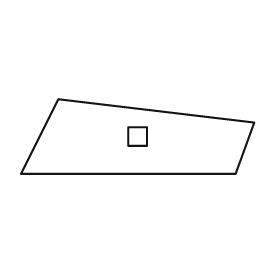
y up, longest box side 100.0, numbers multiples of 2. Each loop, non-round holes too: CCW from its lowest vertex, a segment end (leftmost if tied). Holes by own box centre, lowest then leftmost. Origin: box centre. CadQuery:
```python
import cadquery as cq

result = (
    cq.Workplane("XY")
    .moveTo(-50.0, -16.0)
    .lineTo(42.0, -16.0)
    .lineTo(50.0, 6.0)
    .lineTo(-34.0, 16.0)
    .close()
    .moveTo(-4.0, -4.0)
    .lineTo(4.0, -4.0)
    .lineTo(4.0, 4.0)
    .lineTo(-4.0, 4.0)
    .close()
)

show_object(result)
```